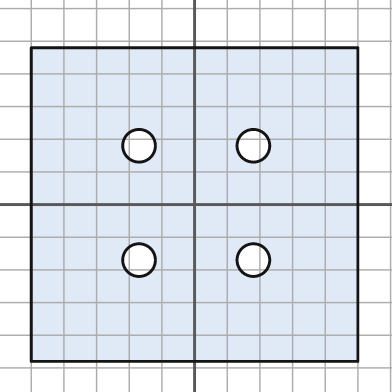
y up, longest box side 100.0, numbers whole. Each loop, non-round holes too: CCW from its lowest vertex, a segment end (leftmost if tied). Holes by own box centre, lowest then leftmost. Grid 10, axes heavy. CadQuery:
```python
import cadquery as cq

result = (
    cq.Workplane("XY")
    .moveTo(-50.0, -48.0)
    .lineTo(50.0, -48.0)
    .lineTo(50.0, 48.0)
    .lineTo(-50.0, 48.0)
    .close()
    .moveTo(-17.0, -17.0)
    .circle(5.0)
    .moveTo(18.0, -17.0)
    .circle(5.0)
    .moveTo(-17.0, 18.0)
    .circle(5.0)
    .moveTo(18.0, 18.0)
    .circle(5.0)
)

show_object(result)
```